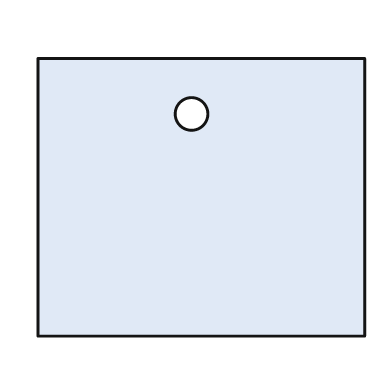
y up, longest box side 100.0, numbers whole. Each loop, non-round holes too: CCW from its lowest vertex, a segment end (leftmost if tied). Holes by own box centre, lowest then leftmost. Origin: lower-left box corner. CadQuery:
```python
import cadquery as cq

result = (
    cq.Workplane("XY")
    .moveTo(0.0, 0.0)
    .lineTo(100.0, 0.0)
    .lineTo(100.0, 85.0)
    .lineTo(0.0, 85.0)
    .close()
    .moveTo(47.0, 68.0)
    .circle(5.0)
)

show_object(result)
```